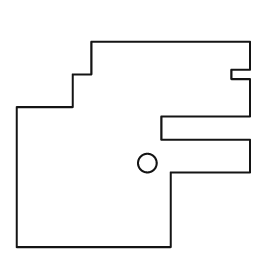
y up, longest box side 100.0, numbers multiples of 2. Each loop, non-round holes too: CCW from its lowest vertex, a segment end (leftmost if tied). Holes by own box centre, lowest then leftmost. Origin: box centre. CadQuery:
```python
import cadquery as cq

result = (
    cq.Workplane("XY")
    .moveTo(-50.0, -44.0)
    .lineTo(16.0, -44.0)
    .lineTo(16.0, -12.0)
    .lineTo(50.0, -12.0)
    .lineTo(50.0, 2.0)
    .lineTo(12.0, 2.0)
    .lineTo(12.0, 12.0)
    .lineTo(50.0, 12.0)
    .lineTo(50.0, 28.0)
    .lineTo(42.0, 28.0)
    .lineTo(42.0, 32.0)
    .lineTo(50.0, 32.0)
    .lineTo(50.0, 44.0)
    .lineTo(-18.0, 44.0)
    .lineTo(-18.0, 30.0)
    .lineTo(-26.0, 30.0)
    .lineTo(-26.0, 16.0)
    .lineTo(-50.0, 16.0)
    .close()
    .moveTo(6.0, -8.0)
    .circle(4.0)
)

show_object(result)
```